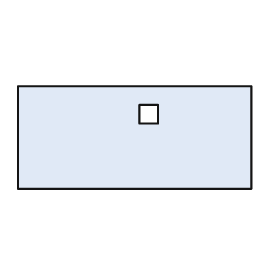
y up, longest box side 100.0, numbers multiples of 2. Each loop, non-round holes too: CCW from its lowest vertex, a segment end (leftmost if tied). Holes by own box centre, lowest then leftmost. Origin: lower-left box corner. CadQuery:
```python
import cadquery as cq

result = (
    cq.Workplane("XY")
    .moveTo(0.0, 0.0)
    .lineTo(100.0, 0.0)
    .lineTo(100.0, 44.0)
    .lineTo(0.0, 44.0)
    .close()
    .moveTo(52.0, 28.0)
    .lineTo(60.0, 28.0)
    .lineTo(60.0, 36.0)
    .lineTo(52.0, 36.0)
    .close()
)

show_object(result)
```